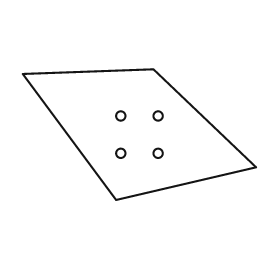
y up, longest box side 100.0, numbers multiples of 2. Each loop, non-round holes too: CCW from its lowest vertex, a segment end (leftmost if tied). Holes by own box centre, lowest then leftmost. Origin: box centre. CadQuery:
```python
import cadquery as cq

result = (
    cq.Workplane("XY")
    .moveTo(-10.0, -28.0)
    .lineTo(50.0, -14.0)
    .lineTo(6.0, 28.0)
    .lineTo(-50.0, 26.0)
    .close()
    .moveTo(-8.0, -8.0)
    .circle(2.0)
    .moveTo(8.0, -8.0)
    .circle(2.0)
    .moveTo(-8.0, 8.0)
    .circle(2.0)
    .moveTo(8.0, 8.0)
    .circle(2.0)
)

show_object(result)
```